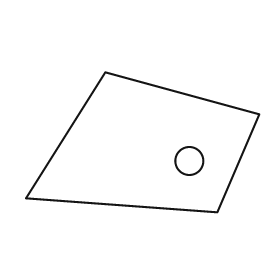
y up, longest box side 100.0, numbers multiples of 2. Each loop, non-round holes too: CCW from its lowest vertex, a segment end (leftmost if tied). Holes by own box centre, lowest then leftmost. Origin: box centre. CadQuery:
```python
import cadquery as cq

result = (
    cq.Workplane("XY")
    .moveTo(32.0, -30.0)
    .lineTo(50.0, 12.0)
    .lineTo(-16.0, 30.0)
    .lineTo(-50.0, -24.0)
    .close()
    .moveTo(20.0, -8.0)
    .circle(6.0)
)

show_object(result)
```